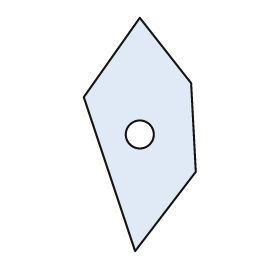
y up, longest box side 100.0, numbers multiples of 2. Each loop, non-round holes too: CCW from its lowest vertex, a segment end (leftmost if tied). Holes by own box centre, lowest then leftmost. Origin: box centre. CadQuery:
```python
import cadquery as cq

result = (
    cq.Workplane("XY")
    .moveTo(-2.0, -50.0)
    .lineTo(24.0, -16.0)
    .lineTo(22.0, 22.0)
    .lineTo(0.0, 50.0)
    .lineTo(-24.0, 16.0)
    .close()
    .moveTo(0.0, 0.0)
    .circle(6.0)
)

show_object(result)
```